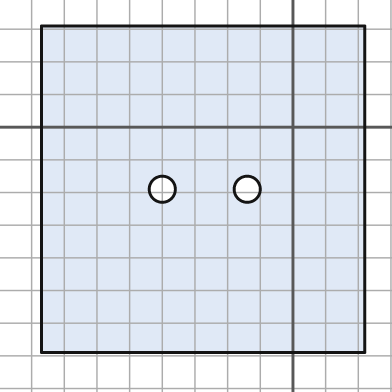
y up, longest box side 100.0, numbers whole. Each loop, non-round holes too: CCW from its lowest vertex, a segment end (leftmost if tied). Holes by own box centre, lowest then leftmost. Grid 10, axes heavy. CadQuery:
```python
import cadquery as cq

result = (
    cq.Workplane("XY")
    .moveTo(-77.0, -69.0)
    .lineTo(22.0, -69.0)
    .lineTo(22.0, 31.0)
    .lineTo(-77.0, 31.0)
    .close()
    .moveTo(-40.0, -19.0)
    .circle(4.0)
    .moveTo(-14.0, -19.0)
    .circle(4.0)
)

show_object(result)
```